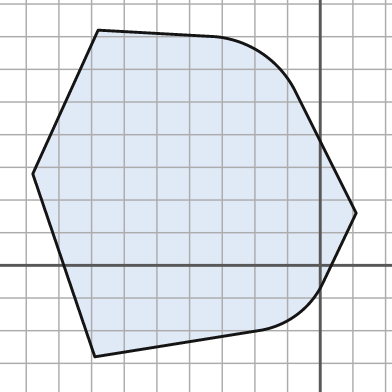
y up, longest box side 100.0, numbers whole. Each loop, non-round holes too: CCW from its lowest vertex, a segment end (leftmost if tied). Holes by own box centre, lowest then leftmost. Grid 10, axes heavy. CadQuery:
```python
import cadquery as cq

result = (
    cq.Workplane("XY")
    .moveTo(-69.0, -28.0)
    .lineTo(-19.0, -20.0)
    .threePointArc((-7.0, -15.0), (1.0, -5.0))
    .lineTo(11.0, 16.0)
    .lineTo(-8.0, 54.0)
    .threePointArc((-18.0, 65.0), (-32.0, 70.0))
    .lineTo(-68.0, 72.0)
    .lineTo(-88.0, 28.0)
    .close()
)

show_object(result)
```